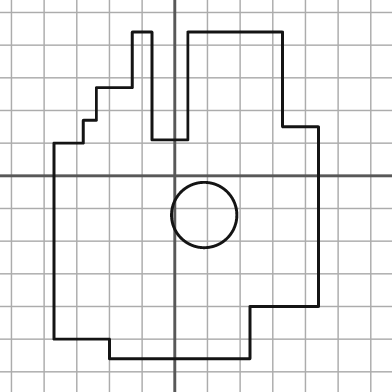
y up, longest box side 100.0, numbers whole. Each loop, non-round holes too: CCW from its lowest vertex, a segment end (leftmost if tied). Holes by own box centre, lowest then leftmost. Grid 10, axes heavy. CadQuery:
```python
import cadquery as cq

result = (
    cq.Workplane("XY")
    .moveTo(-20.0, -56.0)
    .lineTo(23.0, -56.0)
    .lineTo(23.0, -40.0)
    .lineTo(44.0, -40.0)
    .lineTo(44.0, 15.0)
    .lineTo(33.0, 15.0)
    .lineTo(33.0, 44.0)
    .lineTo(4.0, 44.0)
    .lineTo(4.0, 11.0)
    .lineTo(-7.0, 11.0)
    .lineTo(-7.0, 44.0)
    .lineTo(-13.0, 44.0)
    .lineTo(-13.0, 27.0)
    .lineTo(-24.0, 27.0)
    .lineTo(-24.0, 17.0)
    .lineTo(-28.0, 17.0)
    .lineTo(-28.0, 10.0)
    .lineTo(-37.0, 10.0)
    .lineTo(-37.0, -50.0)
    .lineTo(-20.0, -50.0)
    .close()
    .moveTo(9.0, -12.0)
    .circle(10.0)
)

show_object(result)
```